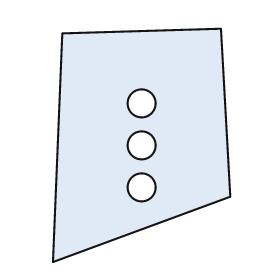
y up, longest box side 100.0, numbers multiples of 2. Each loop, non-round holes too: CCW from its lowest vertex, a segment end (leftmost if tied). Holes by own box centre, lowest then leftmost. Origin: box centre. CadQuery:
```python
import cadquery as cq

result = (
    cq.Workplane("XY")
    .moveTo(-38.0, -50.0)
    .lineTo(38.0, -22.0)
    .lineTo(34.0, 50.0)
    .lineTo(-34.0, 48.0)
    .close()
    .moveTo(0.0, -18.0)
    .circle(6.0)
    .moveTo(0.0, 0.0)
    .circle(6.0)
    .moveTo(0.0, 18.0)
    .circle(6.0)
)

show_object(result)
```